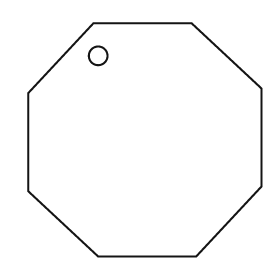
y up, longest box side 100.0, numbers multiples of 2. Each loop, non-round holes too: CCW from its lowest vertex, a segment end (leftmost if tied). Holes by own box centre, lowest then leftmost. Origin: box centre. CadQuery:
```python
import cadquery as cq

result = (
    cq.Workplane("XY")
    .moveTo(-20.0, -50.0)
    .lineTo(22.0, -50.0)
    .lineTo(50.0, -20.0)
    .lineTo(50.0, 22.0)
    .lineTo(20.0, 50.0)
    .lineTo(-22.0, 50.0)
    .lineTo(-50.0, 20.0)
    .lineTo(-50.0, -22.0)
    .close()
    .moveTo(-20.0, 36.0)
    .circle(4.0)
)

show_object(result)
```